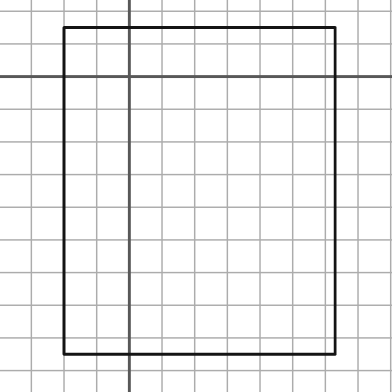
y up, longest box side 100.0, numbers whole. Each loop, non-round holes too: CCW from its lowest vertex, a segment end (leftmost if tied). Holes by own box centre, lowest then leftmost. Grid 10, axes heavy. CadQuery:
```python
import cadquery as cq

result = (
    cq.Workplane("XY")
    .moveTo(-20.0, -85.0)
    .lineTo(63.0, -85.0)
    .lineTo(63.0, 15.0)
    .lineTo(-20.0, 15.0)
    .close()
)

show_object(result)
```